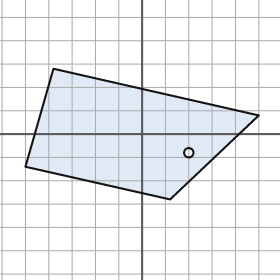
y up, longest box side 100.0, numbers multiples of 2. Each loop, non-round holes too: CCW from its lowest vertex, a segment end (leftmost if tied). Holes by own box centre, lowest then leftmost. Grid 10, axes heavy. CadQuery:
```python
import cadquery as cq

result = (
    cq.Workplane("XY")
    .moveTo(12.0, -28.0)
    .lineTo(50.0, 8.0)
    .lineTo(-38.0, 28.0)
    .lineTo(-50.0, -14.0)
    .close()
    .moveTo(20.0, -8.0)
    .circle(2.0)
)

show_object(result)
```